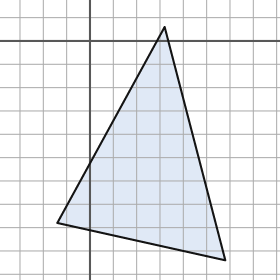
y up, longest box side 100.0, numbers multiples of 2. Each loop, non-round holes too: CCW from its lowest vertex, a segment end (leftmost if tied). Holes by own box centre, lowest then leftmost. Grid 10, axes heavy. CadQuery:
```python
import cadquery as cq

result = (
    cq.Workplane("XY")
    .moveTo(58.0, -94.0)
    .lineTo(32.0, 6.0)
    .lineTo(-14.0, -78.0)
    .close()
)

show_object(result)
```